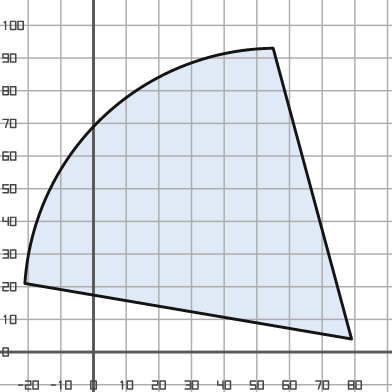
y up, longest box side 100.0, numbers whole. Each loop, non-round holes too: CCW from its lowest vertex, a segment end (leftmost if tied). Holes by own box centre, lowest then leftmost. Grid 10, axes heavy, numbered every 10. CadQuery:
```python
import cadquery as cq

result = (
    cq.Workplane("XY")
    .moveTo(79.0, 4.0)
    .lineTo(55.0, 93.0)
    .threePointArc((3.0, 72.0), (-21.0, 21.0))
    .close()
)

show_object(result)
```